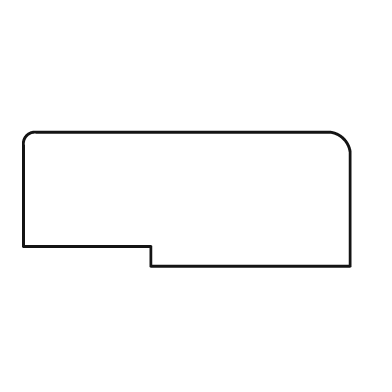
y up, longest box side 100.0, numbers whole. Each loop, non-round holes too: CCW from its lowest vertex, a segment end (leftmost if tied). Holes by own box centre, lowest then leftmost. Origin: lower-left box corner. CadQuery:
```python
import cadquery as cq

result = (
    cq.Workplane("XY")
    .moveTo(39.0, 0.0)
    .lineTo(100.0, 0.0)
    .lineTo(100.0, 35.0)
    .threePointArc((98.0, 39.0), (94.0, 41.0))
    .lineTo(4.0, 41.0)
    .threePointArc((1.0, 40.0), (0.0, 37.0))
    .lineTo(0.0, 6.0)
    .lineTo(39.0, 6.0)
    .close()
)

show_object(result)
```